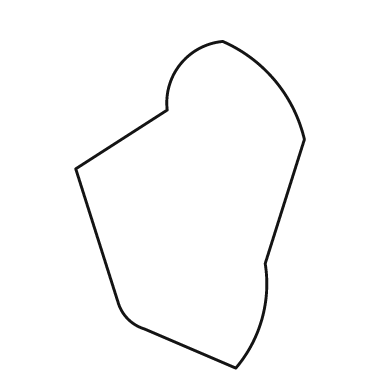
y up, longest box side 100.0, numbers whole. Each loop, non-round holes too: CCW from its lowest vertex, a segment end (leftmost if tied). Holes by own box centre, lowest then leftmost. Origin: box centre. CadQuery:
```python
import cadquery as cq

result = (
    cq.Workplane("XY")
    .moveTo(14.0, -50.0)
    .threePointArc((22.0, -35.0), (23.0, -18.0))
    .lineTo(35.0, 20.0)
    .threePointArc((26.0, 38.0), (10.0, 50.0))
    .threePointArc((-3.0, 43.0), (-7.0, 29.0))
    .lineTo(-35.0, 11.0)
    .lineTo(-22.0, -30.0)
    .threePointArc((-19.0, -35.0), (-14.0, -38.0))
    .close()
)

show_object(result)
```